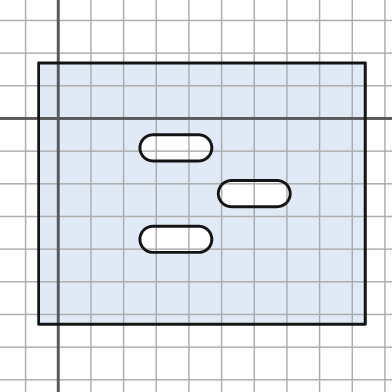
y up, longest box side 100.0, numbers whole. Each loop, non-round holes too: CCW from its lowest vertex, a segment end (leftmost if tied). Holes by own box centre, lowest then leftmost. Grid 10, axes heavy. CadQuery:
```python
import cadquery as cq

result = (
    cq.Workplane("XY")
    .moveTo(-6.0, -63.0)
    .lineTo(94.0, -63.0)
    .lineTo(94.0, 17.0)
    .lineTo(-6.0, 17.0)
    .close()
    .moveTo(29.0, -41.0)
    .lineTo(43.0, -41.0)
    .threePointArc((47.0, -37.0), (43.0, -33.0))
    .lineTo(29.0, -33.0)
    .threePointArc((25.0, -37.0), (29.0, -41.0))
    .close()
    .moveTo(53.0, -27.0)
    .lineTo(67.0, -27.0)
    .threePointArc((71.0, -23.0), (67.0, -19.0))
    .lineTo(53.0, -19.0)
    .threePointArc((49.0, -23.0), (53.0, -27.0))
    .close()
    .moveTo(29.0, -13.0)
    .lineTo(43.0, -13.0)
    .threePointArc((47.0, -9.0), (43.0, -5.0))
    .lineTo(29.0, -5.0)
    .threePointArc((25.0, -9.0), (29.0, -13.0))
    .close()
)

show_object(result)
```